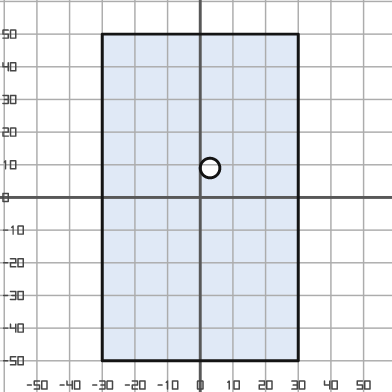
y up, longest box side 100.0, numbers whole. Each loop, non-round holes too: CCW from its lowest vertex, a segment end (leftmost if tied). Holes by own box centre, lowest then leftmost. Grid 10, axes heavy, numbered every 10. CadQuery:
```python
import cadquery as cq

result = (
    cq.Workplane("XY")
    .moveTo(-30.0, -50.0)
    .lineTo(30.0, -50.0)
    .lineTo(30.0, 50.0)
    .lineTo(-30.0, 50.0)
    .close()
    .moveTo(3.0, 9.0)
    .circle(3.0)
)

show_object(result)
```